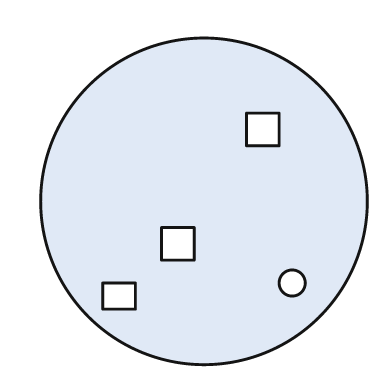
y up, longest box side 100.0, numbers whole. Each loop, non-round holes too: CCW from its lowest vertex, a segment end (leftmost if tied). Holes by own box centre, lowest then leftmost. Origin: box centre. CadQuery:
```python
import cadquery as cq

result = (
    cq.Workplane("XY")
    .moveTo(0.0, 0.0)
    .circle(50.0)
    .moveTo(-31.0, -33.0)
    .lineTo(-21.0, -33.0)
    .lineTo(-21.0, -25.0)
    .lineTo(-31.0, -25.0)
    .close()
    .moveTo(27.0, -25.0)
    .circle(4.0)
    .moveTo(-13.0, -18.0)
    .lineTo(-3.0, -18.0)
    .lineTo(-3.0, -8.0)
    .lineTo(-13.0, -8.0)
    .close()
    .moveTo(13.0, 17.0)
    .lineTo(23.0, 17.0)
    .lineTo(23.0, 27.0)
    .lineTo(13.0, 27.0)
    .close()
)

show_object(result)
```